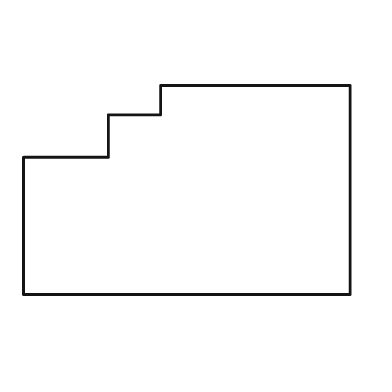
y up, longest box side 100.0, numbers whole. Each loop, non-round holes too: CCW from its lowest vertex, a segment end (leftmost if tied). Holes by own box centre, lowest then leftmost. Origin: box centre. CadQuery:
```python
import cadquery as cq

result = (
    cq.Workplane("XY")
    .moveTo(-50.0, -32.0)
    .lineTo(50.0, -32.0)
    .lineTo(50.0, 32.0)
    .lineTo(-8.0, 32.0)
    .lineTo(-8.0, 23.0)
    .lineTo(-24.0, 23.0)
    .lineTo(-24.0, 10.0)
    .lineTo(-50.0, 10.0)
    .close()
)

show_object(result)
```